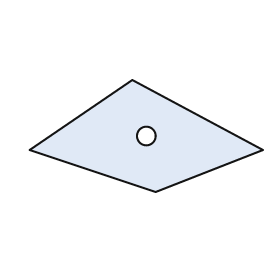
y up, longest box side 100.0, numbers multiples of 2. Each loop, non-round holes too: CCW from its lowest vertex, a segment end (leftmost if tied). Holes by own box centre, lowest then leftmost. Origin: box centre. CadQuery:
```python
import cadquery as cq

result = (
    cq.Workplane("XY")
    .moveTo(4.0, -24.0)
    .lineTo(50.0, -6.0)
    .lineTo(-6.0, 24.0)
    .lineTo(-50.0, -6.0)
    .close()
    .moveTo(0.0, 0.0)
    .circle(4.0)
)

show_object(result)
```